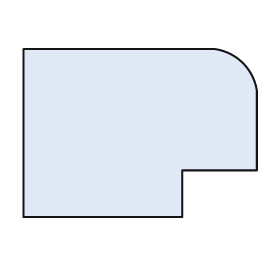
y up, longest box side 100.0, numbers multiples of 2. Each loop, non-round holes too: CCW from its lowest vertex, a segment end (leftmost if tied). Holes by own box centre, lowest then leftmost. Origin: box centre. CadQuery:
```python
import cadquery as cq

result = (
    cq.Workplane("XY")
    .moveTo(-50.0, -36.0)
    .lineTo(18.0, -36.0)
    .lineTo(18.0, -16.0)
    .lineTo(50.0, -16.0)
    .lineTo(50.0, 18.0)
    .threePointArc((44.0, 30.0), (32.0, 36.0))
    .lineTo(-50.0, 36.0)
    .close()
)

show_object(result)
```